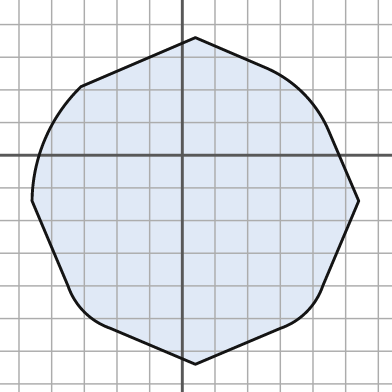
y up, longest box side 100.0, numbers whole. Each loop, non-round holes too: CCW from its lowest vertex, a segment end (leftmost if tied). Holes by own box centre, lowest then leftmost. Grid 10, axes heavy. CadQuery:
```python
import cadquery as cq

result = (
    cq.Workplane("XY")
    .moveTo(4.0, -64.0)
    .lineTo(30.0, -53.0)
    .threePointArc((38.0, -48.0), (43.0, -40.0))
    .lineTo(54.0, -14.0)
    .lineTo(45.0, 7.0)
    .threePointArc((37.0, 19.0), (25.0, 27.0))
    .lineTo(4.0, 36.0)
    .lineTo(-31.0, 21.0)
    .threePointArc((-42.0, 5.0), (-46.0, -14.0))
    .lineTo(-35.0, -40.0)
    .threePointArc((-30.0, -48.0), (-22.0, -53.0))
    .close()
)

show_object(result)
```